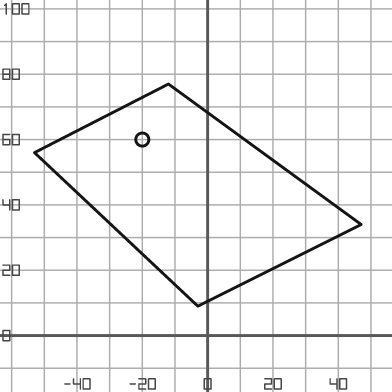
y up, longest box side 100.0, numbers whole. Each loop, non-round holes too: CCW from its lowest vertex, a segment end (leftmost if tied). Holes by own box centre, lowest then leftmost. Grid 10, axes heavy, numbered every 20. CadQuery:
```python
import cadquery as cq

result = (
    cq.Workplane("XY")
    .moveTo(-3.0, 9.0)
    .lineTo(47.0, 34.0)
    .lineTo(-12.0, 77.0)
    .lineTo(-53.0, 56.0)
    .close()
    .moveTo(-20.0, 60.0)
    .circle(2.0)
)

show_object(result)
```